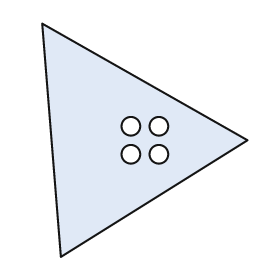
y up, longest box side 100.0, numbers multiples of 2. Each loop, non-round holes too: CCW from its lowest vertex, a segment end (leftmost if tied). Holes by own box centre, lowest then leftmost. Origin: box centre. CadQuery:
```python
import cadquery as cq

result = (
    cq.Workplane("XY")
    .moveTo(-36.0, -50.0)
    .lineTo(44.0, 0.0)
    .lineTo(-44.0, 50.0)
    .close()
    .moveTo(-6.0, -6.0)
    .circle(4.0)
    .moveTo(6.0, -6.0)
    .circle(4.0)
    .moveTo(-6.0, 6.0)
    .circle(4.0)
    .moveTo(6.0, 6.0)
    .circle(4.0)
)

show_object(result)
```